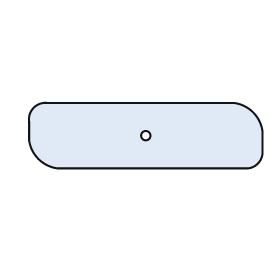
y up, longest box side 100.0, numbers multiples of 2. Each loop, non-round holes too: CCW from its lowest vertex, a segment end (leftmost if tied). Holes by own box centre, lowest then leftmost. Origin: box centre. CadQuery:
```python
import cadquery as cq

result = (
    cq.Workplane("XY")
    .moveTo(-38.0, -14.0)
    .lineTo(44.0, -14.0)
    .threePointArc((48.0, -12.0), (50.0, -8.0))
    .lineTo(50.0, 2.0)
    .threePointArc((46.0, 10.0), (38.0, 14.0))
    .lineTo(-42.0, 14.0)
    .threePointArc((-48.0, 12.0), (-50.0, 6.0))
    .lineTo(-50.0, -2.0)
    .threePointArc((-46.0, -10.0), (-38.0, -14.0))
    .close()
    .moveTo(0.0, 0.0)
    .circle(2.0)
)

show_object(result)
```